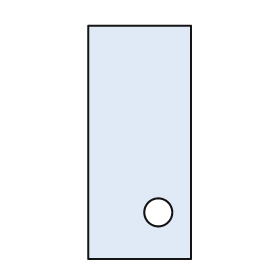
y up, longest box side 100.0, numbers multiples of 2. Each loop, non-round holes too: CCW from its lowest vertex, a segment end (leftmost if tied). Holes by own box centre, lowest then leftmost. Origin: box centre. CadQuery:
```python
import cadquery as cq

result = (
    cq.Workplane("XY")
    .moveTo(-22.0, -50.0)
    .lineTo(22.0, -50.0)
    .lineTo(22.0, 50.0)
    .lineTo(-22.0, 50.0)
    .close()
    .moveTo(8.0, -30.0)
    .circle(6.0)
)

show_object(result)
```